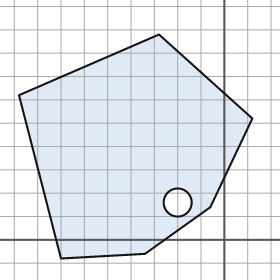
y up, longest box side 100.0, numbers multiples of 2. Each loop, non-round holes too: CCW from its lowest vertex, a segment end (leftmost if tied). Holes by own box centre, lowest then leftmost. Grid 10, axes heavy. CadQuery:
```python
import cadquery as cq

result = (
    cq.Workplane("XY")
    .moveTo(-70.0, -8.0)
    .lineTo(-34.0, -6.0)
    .lineTo(-6.0, 14.0)
    .lineTo(12.0, 52.0)
    .lineTo(-28.0, 88.0)
    .lineTo(-88.0, 62.0)
    .close()
    .moveTo(-20.0, 16.0)
    .circle(6.0)
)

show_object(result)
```